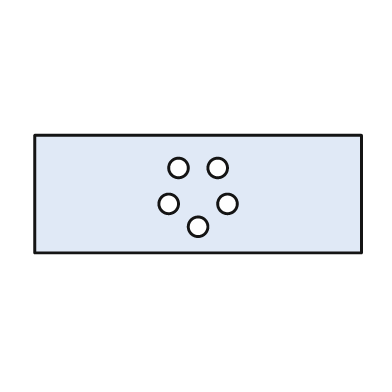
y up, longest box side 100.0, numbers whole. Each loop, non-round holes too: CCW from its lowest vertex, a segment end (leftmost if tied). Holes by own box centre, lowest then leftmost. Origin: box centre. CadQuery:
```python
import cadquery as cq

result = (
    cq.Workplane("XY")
    .moveTo(-50.0, -18.0)
    .lineTo(50.0, -18.0)
    .lineTo(50.0, 18.0)
    .lineTo(-50.0, 18.0)
    .close()
    .moveTo(0.0, -10.0)
    .circle(3.0)
    .moveTo(-9.0, -3.0)
    .circle(3.0)
    .moveTo(9.0, -3.0)
    .circle(3.0)
    .moveTo(-6.0, 8.0)
    .circle(3.0)
    .moveTo(6.0, 8.0)
    .circle(3.0)
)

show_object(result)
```